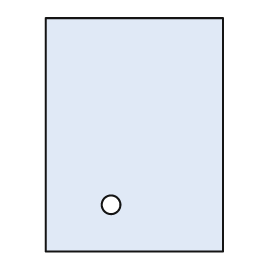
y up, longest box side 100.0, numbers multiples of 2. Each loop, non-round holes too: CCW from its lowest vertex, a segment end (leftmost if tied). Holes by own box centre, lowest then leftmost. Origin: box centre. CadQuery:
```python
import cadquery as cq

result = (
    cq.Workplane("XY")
    .moveTo(-38.0, -50.0)
    .lineTo(38.0, -50.0)
    .lineTo(38.0, 50.0)
    .lineTo(-38.0, 50.0)
    .close()
    .moveTo(-10.0, -30.0)
    .circle(4.0)
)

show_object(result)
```